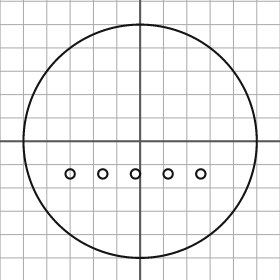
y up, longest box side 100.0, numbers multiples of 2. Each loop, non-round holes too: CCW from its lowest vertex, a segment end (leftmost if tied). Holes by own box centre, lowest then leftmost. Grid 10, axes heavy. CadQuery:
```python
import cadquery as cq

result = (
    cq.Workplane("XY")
    .moveTo(0.0, 0.0)
    .circle(50.0)
    .moveTo(-30.0, -14.0)
    .circle(2.0)
    .moveTo(-16.0, -14.0)
    .circle(2.0)
    .moveTo(-2.0, -14.0)
    .circle(2.0)
    .moveTo(12.0, -14.0)
    .circle(2.0)
    .moveTo(26.0, -14.0)
    .circle(2.0)
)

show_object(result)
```